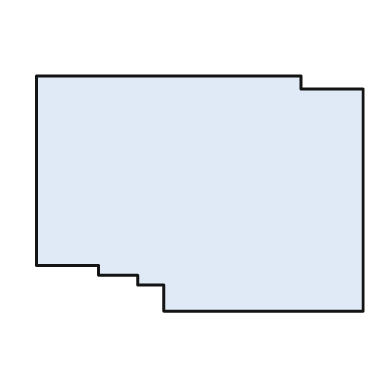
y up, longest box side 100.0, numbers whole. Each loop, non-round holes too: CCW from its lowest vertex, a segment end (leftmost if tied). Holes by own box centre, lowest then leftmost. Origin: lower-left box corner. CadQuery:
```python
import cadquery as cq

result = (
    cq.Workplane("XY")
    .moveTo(39.0, 0.0)
    .lineTo(100.0, 0.0)
    .lineTo(100.0, 68.0)
    .lineTo(81.0, 68.0)
    .lineTo(81.0, 72.0)
    .lineTo(0.0, 72.0)
    .lineTo(0.0, 14.0)
    .lineTo(19.0, 14.0)
    .lineTo(19.0, 11.0)
    .lineTo(31.0, 11.0)
    .lineTo(31.0, 8.0)
    .lineTo(39.0, 8.0)
    .close()
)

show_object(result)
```